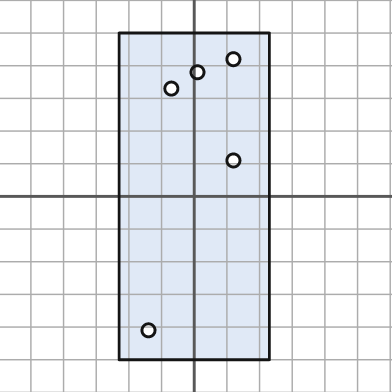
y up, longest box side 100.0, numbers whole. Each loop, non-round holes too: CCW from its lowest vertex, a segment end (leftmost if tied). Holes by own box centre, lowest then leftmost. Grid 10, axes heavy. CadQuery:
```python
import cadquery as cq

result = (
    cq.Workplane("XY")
    .moveTo(-23.0, -50.0)
    .lineTo(23.0, -50.0)
    .lineTo(23.0, 50.0)
    .lineTo(-23.0, 50.0)
    .close()
    .moveTo(-14.0, -41.0)
    .circle(2.0)
    .moveTo(12.0, 11.0)
    .circle(2.0)
    .moveTo(-7.0, 33.0)
    .circle(2.0)
    .moveTo(1.0, 38.0)
    .circle(2.0)
    .moveTo(12.0, 42.0)
    .circle(2.0)
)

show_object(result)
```